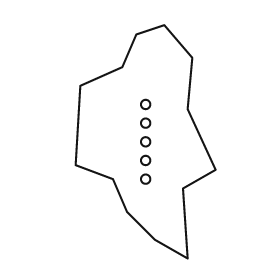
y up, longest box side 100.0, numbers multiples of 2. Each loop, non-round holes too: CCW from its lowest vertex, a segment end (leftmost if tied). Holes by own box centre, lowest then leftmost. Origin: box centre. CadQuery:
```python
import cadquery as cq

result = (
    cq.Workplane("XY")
    .moveTo(18.0, -50.0)
    .lineTo(16.0, -20.0)
    .lineTo(30.0, -12.0)
    .lineTo(18.0, 14.0)
    .lineTo(20.0, 36.0)
    .lineTo(8.0, 50.0)
    .lineTo(-4.0, 46.0)
    .lineTo(-10.0, 32.0)
    .lineTo(-28.0, 24.0)
    .lineTo(-30.0, -10.0)
    .lineTo(-14.0, -16.0)
    .lineTo(-8.0, -30.0)
    .lineTo(4.0, -42.0)
    .close()
    .moveTo(0.0, -16.0)
    .circle(2.0)
    .moveTo(0.0, -8.0)
    .circle(2.0)
    .moveTo(0.0, 0.0)
    .circle(2.0)
    .moveTo(0.0, 8.0)
    .circle(2.0)
    .moveTo(0.0, 16.0)
    .circle(2.0)
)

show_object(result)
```